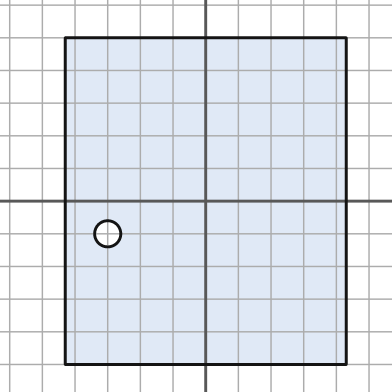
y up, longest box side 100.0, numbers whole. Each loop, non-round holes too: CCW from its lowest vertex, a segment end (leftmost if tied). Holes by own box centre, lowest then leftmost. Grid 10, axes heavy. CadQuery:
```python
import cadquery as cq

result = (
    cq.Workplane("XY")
    .moveTo(-43.0, -50.0)
    .lineTo(43.0, -50.0)
    .lineTo(43.0, 50.0)
    .lineTo(-43.0, 50.0)
    .close()
    .moveTo(-30.0, -10.0)
    .circle(4.0)
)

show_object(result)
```